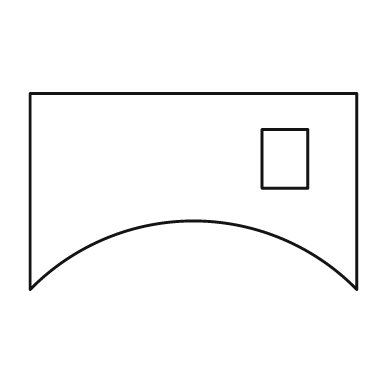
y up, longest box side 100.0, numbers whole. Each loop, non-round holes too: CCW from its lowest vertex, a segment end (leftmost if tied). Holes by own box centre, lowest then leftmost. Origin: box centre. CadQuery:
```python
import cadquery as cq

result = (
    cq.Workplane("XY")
    .moveTo(-50.0, -30.0)
    .threePointArc((0.0, -9.0), (50.0, -30.0))
    .lineTo(50.0, 30.0)
    .lineTo(-50.0, 30.0)
    .close()
    .moveTo(21.0, 1.0)
    .lineTo(35.0, 1.0)
    .lineTo(35.0, 19.0)
    .lineTo(21.0, 19.0)
    .close()
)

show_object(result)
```